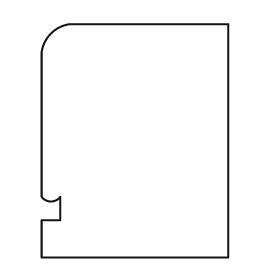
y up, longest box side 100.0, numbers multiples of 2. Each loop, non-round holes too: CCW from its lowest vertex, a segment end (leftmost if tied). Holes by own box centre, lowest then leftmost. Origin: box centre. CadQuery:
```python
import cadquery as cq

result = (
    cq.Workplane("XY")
    .moveTo(-40.0, -50.0)
    .lineTo(40.0, -50.0)
    .lineTo(40.0, 50.0)
    .lineTo(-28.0, 50.0)
    .threePointArc((-36.0, 46.0), (-40.0, 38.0))
    .lineTo(-40.0, -24.0)
    .threePointArc((-36.0, -26.0), (-32.0, -24.0))
    .lineTo(-32.0, -34.0)
    .lineTo(-40.0, -34.0)
    .close()
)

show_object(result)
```